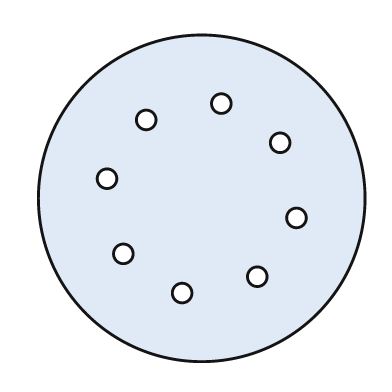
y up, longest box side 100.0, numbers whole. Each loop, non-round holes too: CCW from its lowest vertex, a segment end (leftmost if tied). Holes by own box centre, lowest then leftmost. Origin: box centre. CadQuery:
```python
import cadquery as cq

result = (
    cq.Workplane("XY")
    .moveTo(0.0, 0.0)
    .circle(50.0)
    .moveTo(-6.0, -29.0)
    .circle(3.0)
    .moveTo(17.0, -24.0)
    .circle(3.0)
    .moveTo(-24.0, -17.0)
    .circle(3.0)
    .moveTo(29.0, -6.0)
    .circle(3.0)
    .moveTo(-29.0, 6.0)
    .circle(3.0)
    .moveTo(24.0, 17.0)
    .circle(3.0)
    .moveTo(-17.0, 24.0)
    .circle(3.0)
    .moveTo(6.0, 29.0)
    .circle(3.0)
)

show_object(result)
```